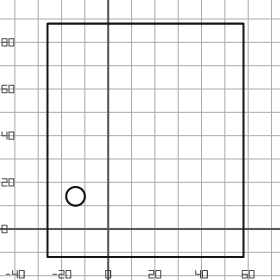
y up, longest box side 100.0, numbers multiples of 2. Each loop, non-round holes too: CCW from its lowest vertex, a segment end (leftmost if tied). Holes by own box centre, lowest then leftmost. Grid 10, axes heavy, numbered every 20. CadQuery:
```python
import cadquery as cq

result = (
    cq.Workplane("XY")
    .moveTo(-26.0, -12.0)
    .lineTo(58.0, -12.0)
    .lineTo(58.0, 88.0)
    .lineTo(-26.0, 88.0)
    .close()
    .moveTo(-14.0, 14.0)
    .circle(4.0)
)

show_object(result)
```